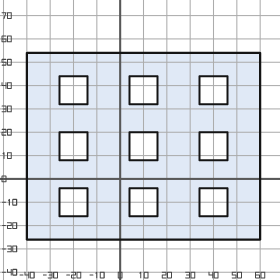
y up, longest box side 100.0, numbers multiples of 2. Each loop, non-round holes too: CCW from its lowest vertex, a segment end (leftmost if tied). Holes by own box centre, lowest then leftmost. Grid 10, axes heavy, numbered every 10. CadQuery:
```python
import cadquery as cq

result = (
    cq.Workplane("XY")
    .moveTo(-40.0, -26.0)
    .lineTo(60.0, -26.0)
    .lineTo(60.0, 54.0)
    .lineTo(-40.0, 54.0)
    .close()
    .moveTo(-26.0, -16.0)
    .lineTo(-14.0, -16.0)
    .lineTo(-14.0, -4.0)
    .lineTo(-26.0, -4.0)
    .close()
    .moveTo(4.0, -16.0)
    .lineTo(16.0, -16.0)
    .lineTo(16.0, -4.0)
    .lineTo(4.0, -4.0)
    .close()
    .moveTo(34.0, -16.0)
    .lineTo(46.0, -16.0)
    .lineTo(46.0, -4.0)
    .lineTo(34.0, -4.0)
    .close()
    .moveTo(-26.0, 8.0)
    .lineTo(-14.0, 8.0)
    .lineTo(-14.0, 20.0)
    .lineTo(-26.0, 20.0)
    .close()
    .moveTo(4.0, 8.0)
    .lineTo(16.0, 8.0)
    .lineTo(16.0, 20.0)
    .lineTo(4.0, 20.0)
    .close()
    .moveTo(34.0, 8.0)
    .lineTo(46.0, 8.0)
    .lineTo(46.0, 20.0)
    .lineTo(34.0, 20.0)
    .close()
    .moveTo(-26.0, 32.0)
    .lineTo(-14.0, 32.0)
    .lineTo(-14.0, 44.0)
    .lineTo(-26.0, 44.0)
    .close()
    .moveTo(4.0, 32.0)
    .lineTo(16.0, 32.0)
    .lineTo(16.0, 44.0)
    .lineTo(4.0, 44.0)
    .close()
    .moveTo(34.0, 32.0)
    .lineTo(46.0, 32.0)
    .lineTo(46.0, 44.0)
    .lineTo(34.0, 44.0)
    .close()
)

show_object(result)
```